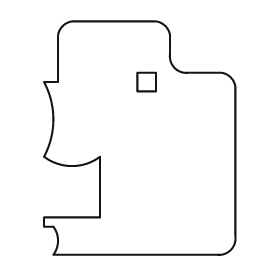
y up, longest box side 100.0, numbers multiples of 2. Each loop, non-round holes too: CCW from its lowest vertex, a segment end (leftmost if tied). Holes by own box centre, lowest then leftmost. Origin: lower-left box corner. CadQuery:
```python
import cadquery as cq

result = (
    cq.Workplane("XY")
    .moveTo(4.0, 0.0)
    .lineTo(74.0, 0.0)
    .threePointArc((80.0, 2.0), (82.0, 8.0))
    .lineTo(82.0, 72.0)
    .threePointArc((80.0, 76.0), (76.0, 78.0))
    .lineTo(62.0, 78.0)
    .threePointArc((56.0, 80.0), (54.0, 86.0))
    .lineTo(54.0, 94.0)
    .threePointArc((52.0, 98.0), (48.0, 100.0))
    .lineTo(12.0, 100.0)
    .threePointArc((8.0, 98.0), (6.0, 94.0))
    .lineTo(6.0, 74.0)
    .lineTo(0.0, 74.0)
    .threePointArc((4.0, 58.0), (0.0, 42.0))
    .threePointArc((12.0, 38.0), (24.0, 42.0))
    .lineTo(24.0, 16.0)
    .lineTo(0.0, 16.0)
    .lineTo(0.0, 12.0)
    .lineTo(4.0, 12.0)
    .threePointArc((6.0, 6.0), (4.0, 0.0))
    .close()
    .moveTo(40.0, 70.0)
    .lineTo(48.0, 70.0)
    .lineTo(48.0, 78.0)
    .lineTo(40.0, 78.0)
    .close()
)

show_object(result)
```